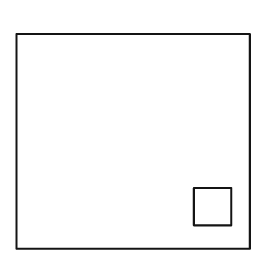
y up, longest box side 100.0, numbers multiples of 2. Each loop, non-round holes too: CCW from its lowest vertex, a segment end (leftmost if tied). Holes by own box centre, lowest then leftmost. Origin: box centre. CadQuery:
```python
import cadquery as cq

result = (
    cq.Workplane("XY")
    .moveTo(-50.0, -46.0)
    .lineTo(50.0, -46.0)
    .lineTo(50.0, 46.0)
    .lineTo(-50.0, 46.0)
    .close()
    .moveTo(26.0, -36.0)
    .lineTo(42.0, -36.0)
    .lineTo(42.0, -20.0)
    .lineTo(26.0, -20.0)
    .close()
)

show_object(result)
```